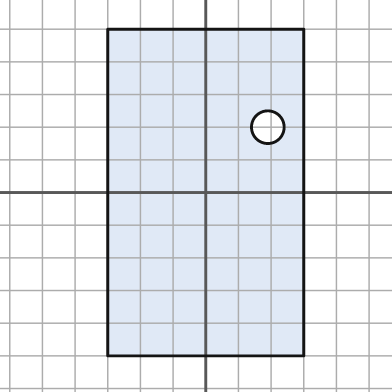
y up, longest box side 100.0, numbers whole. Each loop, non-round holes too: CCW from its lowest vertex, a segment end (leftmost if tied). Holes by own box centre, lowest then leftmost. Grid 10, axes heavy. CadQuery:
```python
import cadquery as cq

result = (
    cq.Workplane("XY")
    .moveTo(-30.0, -50.0)
    .lineTo(30.0, -50.0)
    .lineTo(30.0, 50.0)
    .lineTo(-30.0, 50.0)
    .close()
    .moveTo(19.0, 20.0)
    .circle(5.0)
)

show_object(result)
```